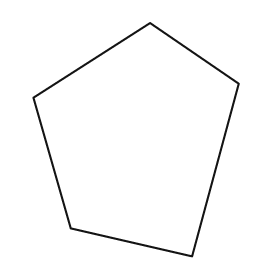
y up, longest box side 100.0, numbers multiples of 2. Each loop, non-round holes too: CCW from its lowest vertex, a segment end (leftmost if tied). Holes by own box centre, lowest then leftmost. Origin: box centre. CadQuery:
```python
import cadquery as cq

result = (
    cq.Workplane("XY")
    .moveTo(24.0, -50.0)
    .lineTo(44.0, 24.0)
    .lineTo(6.0, 50.0)
    .lineTo(-44.0, 18.0)
    .lineTo(-28.0, -38.0)
    .close()
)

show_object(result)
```